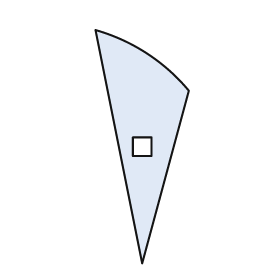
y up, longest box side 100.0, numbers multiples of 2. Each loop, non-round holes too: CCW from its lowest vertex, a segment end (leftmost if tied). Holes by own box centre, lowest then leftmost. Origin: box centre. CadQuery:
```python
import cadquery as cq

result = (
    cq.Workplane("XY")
    .moveTo(0.0, -50.0)
    .lineTo(20.0, 24.0)
    .threePointArc((2.0, 40.0), (-20.0, 50.0))
    .close()
    .moveTo(-4.0, -4.0)
    .lineTo(4.0, -4.0)
    .lineTo(4.0, 4.0)
    .lineTo(-4.0, 4.0)
    .close()
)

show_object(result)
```